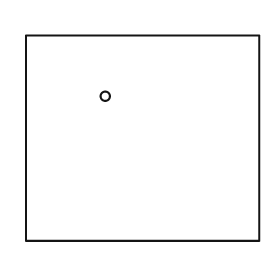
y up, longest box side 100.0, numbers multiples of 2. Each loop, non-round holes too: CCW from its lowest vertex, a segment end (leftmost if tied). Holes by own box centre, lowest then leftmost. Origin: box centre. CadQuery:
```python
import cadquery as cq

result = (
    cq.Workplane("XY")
    .moveTo(-50.0, -44.0)
    .lineTo(50.0, -44.0)
    .lineTo(50.0, 44.0)
    .lineTo(-50.0, 44.0)
    .close()
    .moveTo(-16.0, 18.0)
    .circle(2.0)
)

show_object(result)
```